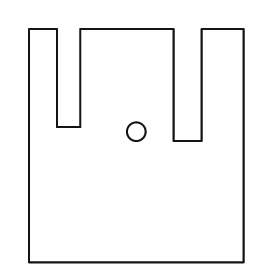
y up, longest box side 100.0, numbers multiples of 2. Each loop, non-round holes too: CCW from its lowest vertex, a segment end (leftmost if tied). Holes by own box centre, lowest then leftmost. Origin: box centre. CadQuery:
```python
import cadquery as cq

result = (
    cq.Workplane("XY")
    .moveTo(-46.0, -50.0)
    .lineTo(46.0, -50.0)
    .lineTo(46.0, 50.0)
    .lineTo(28.0, 50.0)
    .lineTo(28.0, 2.0)
    .lineTo(16.0, 2.0)
    .lineTo(16.0, 50.0)
    .lineTo(-24.0, 50.0)
    .lineTo(-24.0, 8.0)
    .lineTo(-34.0, 8.0)
    .lineTo(-34.0, 50.0)
    .lineTo(-46.0, 50.0)
    .close()
    .moveTo(0.0, 6.0)
    .circle(4.0)
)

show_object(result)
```